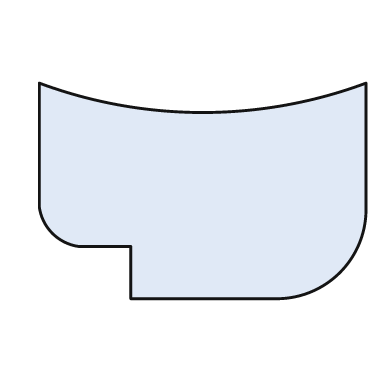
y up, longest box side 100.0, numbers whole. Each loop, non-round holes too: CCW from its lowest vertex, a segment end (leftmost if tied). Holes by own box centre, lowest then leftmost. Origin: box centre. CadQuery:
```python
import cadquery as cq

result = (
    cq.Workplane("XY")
    .moveTo(-22.0, -33.0)
    .lineTo(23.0, -33.0)
    .threePointArc((42.0, -25.0), (50.0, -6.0))
    .lineTo(50.0, 33.0)
    .threePointArc((0.0, 24.0), (-50.0, 33.0))
    .lineTo(-50.0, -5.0)
    .threePointArc((-46.0, -13.0), (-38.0, -17.0))
    .lineTo(-22.0, -17.0)
    .close()
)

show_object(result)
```